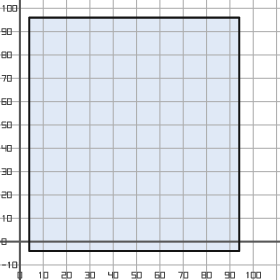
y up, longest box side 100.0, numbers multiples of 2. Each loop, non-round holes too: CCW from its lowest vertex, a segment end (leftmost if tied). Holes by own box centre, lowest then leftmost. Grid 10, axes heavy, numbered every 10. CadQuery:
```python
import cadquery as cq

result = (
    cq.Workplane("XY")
    .moveTo(4.0, -4.0)
    .lineTo(94.0, -4.0)
    .lineTo(94.0, 96.0)
    .lineTo(4.0, 96.0)
    .close()
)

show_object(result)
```